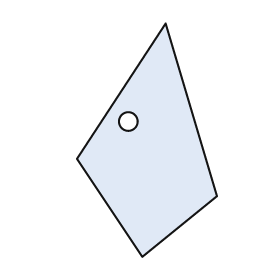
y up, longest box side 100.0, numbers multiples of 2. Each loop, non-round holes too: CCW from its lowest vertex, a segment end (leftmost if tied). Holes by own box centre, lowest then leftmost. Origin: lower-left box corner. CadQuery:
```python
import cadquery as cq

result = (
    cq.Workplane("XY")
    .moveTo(28.0, 0.0)
    .lineTo(60.0, 26.0)
    .lineTo(38.0, 100.0)
    .lineTo(0.0, 42.0)
    .close()
    .moveTo(22.0, 58.0)
    .circle(4.0)
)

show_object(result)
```